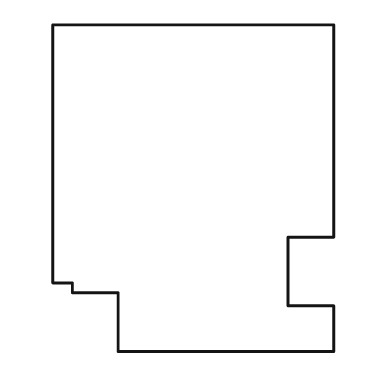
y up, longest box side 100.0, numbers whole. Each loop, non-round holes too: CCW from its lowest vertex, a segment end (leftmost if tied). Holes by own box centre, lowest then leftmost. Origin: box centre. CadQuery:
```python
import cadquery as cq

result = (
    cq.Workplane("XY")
    .moveTo(-23.0, -50.0)
    .lineTo(43.0, -50.0)
    .lineTo(43.0, -36.0)
    .lineTo(29.0, -36.0)
    .lineTo(29.0, -15.0)
    .lineTo(43.0, -15.0)
    .lineTo(43.0, 50.0)
    .lineTo(-43.0, 50.0)
    .lineTo(-43.0, -29.0)
    .lineTo(-37.0, -29.0)
    .lineTo(-37.0, -32.0)
    .lineTo(-23.0, -32.0)
    .close()
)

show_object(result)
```